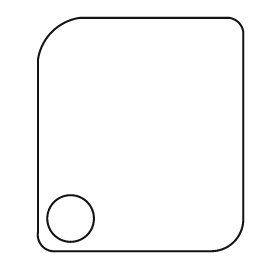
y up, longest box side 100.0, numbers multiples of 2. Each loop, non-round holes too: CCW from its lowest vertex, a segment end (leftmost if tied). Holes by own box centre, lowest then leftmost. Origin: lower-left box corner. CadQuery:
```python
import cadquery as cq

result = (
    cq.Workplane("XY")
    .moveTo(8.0, 0.0)
    .lineTo(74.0, 0.0)
    .threePointArc((84.0, 4.0), (88.0, 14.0))
    .lineTo(88.0, 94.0)
    .threePointArc((86.0, 98.0), (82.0, 100.0))
    .lineTo(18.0, 100.0)
    .threePointArc((6.0, 94.0), (0.0, 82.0))
    .lineTo(0.0, 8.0)
    .threePointArc((2.0, 2.0), (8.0, 0.0))
    .close()
    .moveTo(14.0, 14.0)
    .circle(10.0)
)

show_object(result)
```